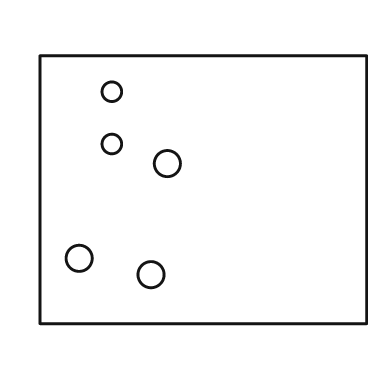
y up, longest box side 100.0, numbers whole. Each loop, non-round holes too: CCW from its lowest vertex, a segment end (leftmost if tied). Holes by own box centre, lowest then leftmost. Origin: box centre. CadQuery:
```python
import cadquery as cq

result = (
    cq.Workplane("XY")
    .moveTo(-50.0, -41.0)
    .lineTo(50.0, -41.0)
    .lineTo(50.0, 41.0)
    .lineTo(-50.0, 41.0)
    .close()
    .moveTo(-16.0, -26.0)
    .circle(4.0)
    .moveTo(-38.0, -21.0)
    .circle(4.0)
    .moveTo(-11.0, 8.0)
    .circle(4.0)
    .moveTo(-28.0, 14.0)
    .circle(3.0)
    .moveTo(-28.0, 30.0)
    .circle(3.0)
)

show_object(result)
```